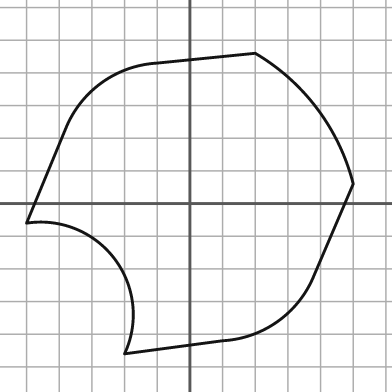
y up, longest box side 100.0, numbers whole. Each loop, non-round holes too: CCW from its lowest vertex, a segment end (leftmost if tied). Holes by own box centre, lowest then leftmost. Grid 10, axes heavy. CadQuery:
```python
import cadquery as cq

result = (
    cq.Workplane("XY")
    .moveTo(-20.0, -46.0)
    .lineTo(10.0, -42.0)
    .threePointArc((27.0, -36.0), (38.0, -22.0))
    .lineTo(50.0, 6.0)
    .threePointArc((39.0, 29.0), (20.0, 46.0))
    .lineTo(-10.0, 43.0)
    .threePointArc((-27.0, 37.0), (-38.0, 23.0))
    .lineTo(-50.0, -6.0)
    .threePointArc((-23.0, -17.0), (-20.0, -46.0))
    .close()
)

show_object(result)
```